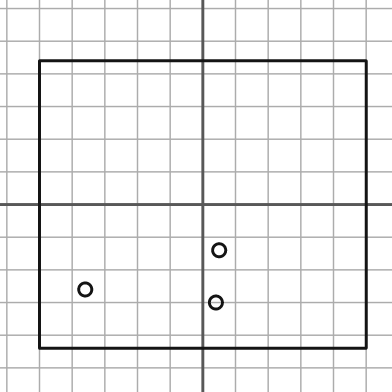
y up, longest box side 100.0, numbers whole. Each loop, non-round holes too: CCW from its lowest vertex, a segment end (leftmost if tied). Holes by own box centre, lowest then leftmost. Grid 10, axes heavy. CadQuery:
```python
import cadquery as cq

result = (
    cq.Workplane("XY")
    .moveTo(-50.0, -44.0)
    .lineTo(50.0, -44.0)
    .lineTo(50.0, 44.0)
    .lineTo(-50.0, 44.0)
    .close()
    .moveTo(4.0, -30.0)
    .circle(2.0)
    .moveTo(-36.0, -26.0)
    .circle(2.0)
    .moveTo(5.0, -14.0)
    .circle(2.0)
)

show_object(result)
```